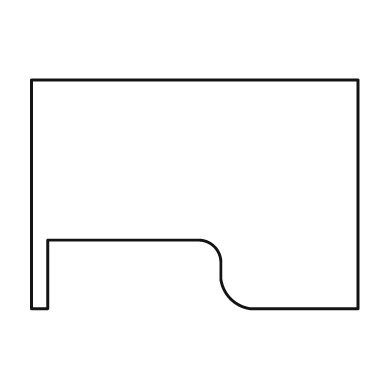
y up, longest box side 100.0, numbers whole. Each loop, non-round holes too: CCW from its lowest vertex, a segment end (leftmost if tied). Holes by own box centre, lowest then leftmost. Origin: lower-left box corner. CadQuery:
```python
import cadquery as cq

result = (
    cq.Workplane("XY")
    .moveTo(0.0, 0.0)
    .lineTo(5.0, 0.0)
    .lineTo(5.0, 21.0)
    .lineTo(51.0, 21.0)
    .threePointArc((56.0, 19.0), (58.0, 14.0))
    .lineTo(58.0, 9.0)
    .threePointArc((61.0, 3.0), (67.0, 0.0))
    .lineTo(100.0, 0.0)
    .lineTo(100.0, 70.0)
    .lineTo(0.0, 70.0)
    .close()
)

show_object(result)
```